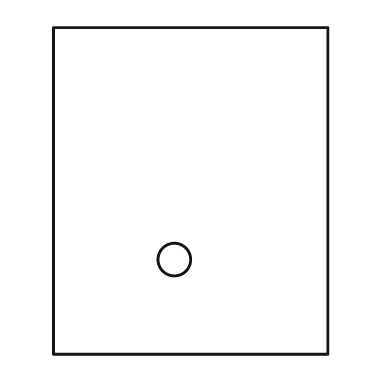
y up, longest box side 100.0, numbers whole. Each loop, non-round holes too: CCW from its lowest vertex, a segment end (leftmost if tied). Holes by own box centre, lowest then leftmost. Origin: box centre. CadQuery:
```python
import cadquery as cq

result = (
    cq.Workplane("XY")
    .moveTo(-42.0, -50.0)
    .lineTo(42.0, -50.0)
    .lineTo(42.0, 50.0)
    .lineTo(-42.0, 50.0)
    .close()
    .moveTo(-5.0, -21.0)
    .circle(5.0)
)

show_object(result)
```